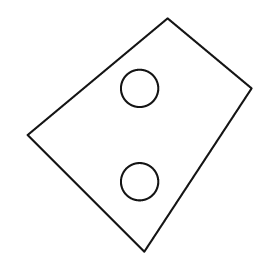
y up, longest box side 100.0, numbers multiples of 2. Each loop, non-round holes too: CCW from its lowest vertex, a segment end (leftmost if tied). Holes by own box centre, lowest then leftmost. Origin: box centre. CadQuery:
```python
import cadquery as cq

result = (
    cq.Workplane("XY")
    .moveTo(2.0, -50.0)
    .lineTo(48.0, 20.0)
    .lineTo(12.0, 50.0)
    .lineTo(-48.0, 0.0)
    .close()
    .moveTo(0.0, -20.0)
    .circle(8.0)
    .moveTo(0.0, 20.0)
    .circle(8.0)
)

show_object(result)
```